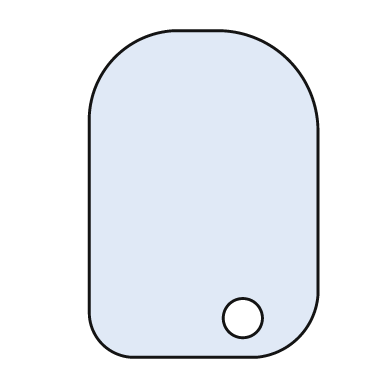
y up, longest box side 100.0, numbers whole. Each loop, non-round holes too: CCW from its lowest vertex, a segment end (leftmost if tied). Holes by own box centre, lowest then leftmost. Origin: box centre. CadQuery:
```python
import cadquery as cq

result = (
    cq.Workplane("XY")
    .moveTo(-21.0, -50.0)
    .lineTo(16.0, -50.0)
    .threePointArc((29.0, -44.0), (35.0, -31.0))
    .lineTo(35.0, 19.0)
    .threePointArc((26.0, 41.0), (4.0, 50.0))
    .lineTo(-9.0, 50.0)
    .threePointArc((-27.0, 42.0), (-35.0, 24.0))
    .lineTo(-35.0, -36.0)
    .threePointArc((-31.0, -46.0), (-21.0, -50.0))
    .close()
    .moveTo(12.0, -38.0)
    .circle(6.0)
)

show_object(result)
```